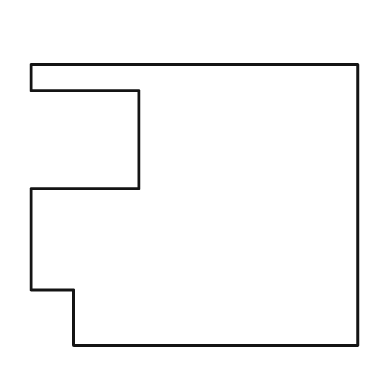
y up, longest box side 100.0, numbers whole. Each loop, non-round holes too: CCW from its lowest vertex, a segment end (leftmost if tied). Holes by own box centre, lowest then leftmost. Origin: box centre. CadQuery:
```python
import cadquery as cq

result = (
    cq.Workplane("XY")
    .moveTo(-37.0, -43.0)
    .lineTo(50.0, -43.0)
    .lineTo(50.0, 43.0)
    .lineTo(-50.0, 43.0)
    .lineTo(-50.0, 35.0)
    .lineTo(-17.0, 35.0)
    .lineTo(-17.0, 5.0)
    .lineTo(-50.0, 5.0)
    .lineTo(-50.0, -26.0)
    .lineTo(-37.0, -26.0)
    .close()
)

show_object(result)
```